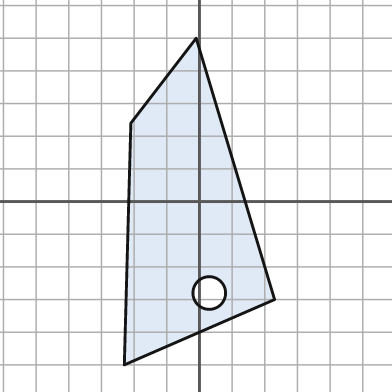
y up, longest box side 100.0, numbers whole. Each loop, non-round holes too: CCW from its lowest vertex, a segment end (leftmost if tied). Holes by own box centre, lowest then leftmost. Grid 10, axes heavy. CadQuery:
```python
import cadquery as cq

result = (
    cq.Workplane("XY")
    .moveTo(-23.0, -50.0)
    .lineTo(23.0, -30.0)
    .lineTo(-1.0, 50.0)
    .lineTo(-21.0, 24.0)
    .close()
    .moveTo(3.0, -28.0)
    .circle(5.0)
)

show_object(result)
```